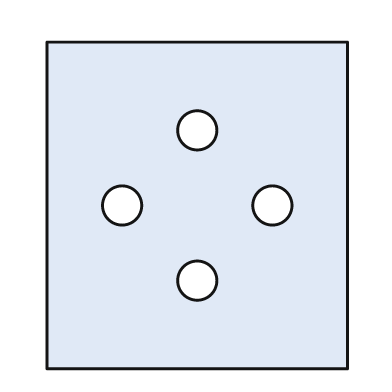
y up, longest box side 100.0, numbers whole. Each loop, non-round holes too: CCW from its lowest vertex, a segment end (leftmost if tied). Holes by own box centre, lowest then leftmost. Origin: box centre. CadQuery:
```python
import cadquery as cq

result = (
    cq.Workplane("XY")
    .moveTo(-46.0, -50.0)
    .lineTo(46.0, -50.0)
    .lineTo(46.0, 50.0)
    .lineTo(-46.0, 50.0)
    .close()
    .moveTo(0.0, -23.0)
    .circle(6.0)
    .moveTo(-23.0, 0.0)
    .circle(6.0)
    .moveTo(23.0, 0.0)
    .circle(6.0)
    .moveTo(0.0, 23.0)
    .circle(6.0)
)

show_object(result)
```